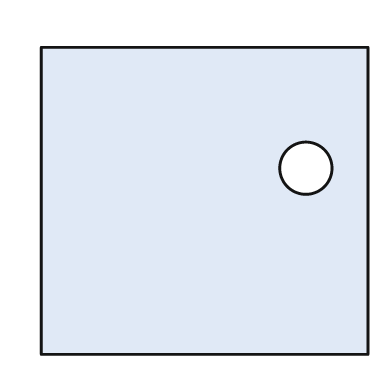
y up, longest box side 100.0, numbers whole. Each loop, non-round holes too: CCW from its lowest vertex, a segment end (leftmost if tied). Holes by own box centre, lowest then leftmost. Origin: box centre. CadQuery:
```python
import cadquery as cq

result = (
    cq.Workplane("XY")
    .moveTo(-50.0, -47.0)
    .lineTo(50.0, -47.0)
    .lineTo(50.0, 47.0)
    .lineTo(-50.0, 47.0)
    .close()
    .moveTo(31.0, 10.0)
    .circle(8.0)
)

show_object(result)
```